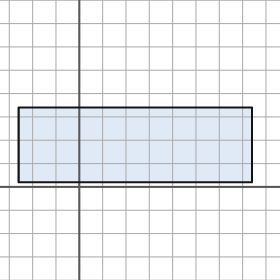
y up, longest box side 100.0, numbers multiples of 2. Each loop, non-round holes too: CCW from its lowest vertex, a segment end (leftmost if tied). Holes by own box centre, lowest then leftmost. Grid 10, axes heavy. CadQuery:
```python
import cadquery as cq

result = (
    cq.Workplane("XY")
    .moveTo(-26.0, 2.0)
    .lineTo(74.0, 2.0)
    .lineTo(74.0, 34.0)
    .lineTo(-26.0, 34.0)
    .close()
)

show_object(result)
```